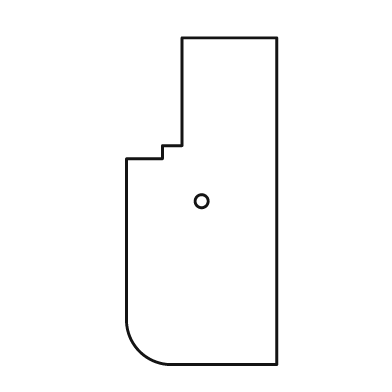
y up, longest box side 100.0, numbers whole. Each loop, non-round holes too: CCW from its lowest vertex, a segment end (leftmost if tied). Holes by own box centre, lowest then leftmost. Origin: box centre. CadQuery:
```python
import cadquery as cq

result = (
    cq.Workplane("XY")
    .moveTo(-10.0, -50.0)
    .lineTo(23.0, -50.0)
    .lineTo(23.0, 50.0)
    .lineTo(-6.0, 50.0)
    .lineTo(-6.0, 17.0)
    .lineTo(-12.0, 17.0)
    .lineTo(-12.0, 13.0)
    .lineTo(-23.0, 13.0)
    .lineTo(-23.0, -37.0)
    .threePointArc((-19.0, -46.0), (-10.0, -50.0))
    .close()
    .moveTo(0.0, 0.0)
    .circle(2.0)
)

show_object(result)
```